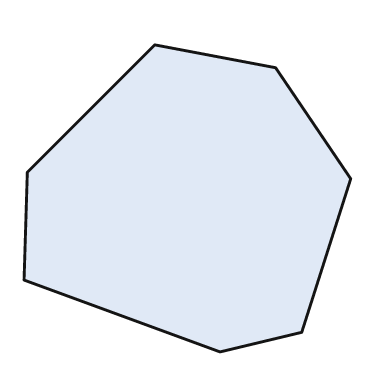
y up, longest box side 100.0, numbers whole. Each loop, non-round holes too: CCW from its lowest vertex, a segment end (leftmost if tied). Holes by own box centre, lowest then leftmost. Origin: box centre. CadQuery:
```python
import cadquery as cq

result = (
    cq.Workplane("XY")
    .moveTo(10.0, -47.0)
    .lineTo(35.0, -41.0)
    .lineTo(50.0, 6.0)
    .lineTo(27.0, 40.0)
    .lineTo(-10.0, 47.0)
    .lineTo(-49.0, 8.0)
    .lineTo(-50.0, -25.0)
    .close()
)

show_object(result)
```